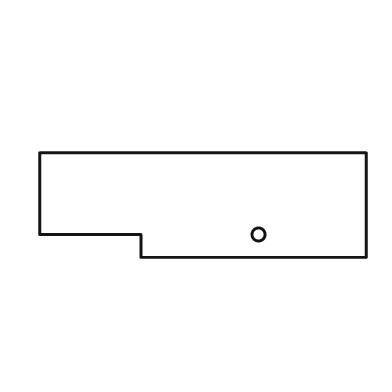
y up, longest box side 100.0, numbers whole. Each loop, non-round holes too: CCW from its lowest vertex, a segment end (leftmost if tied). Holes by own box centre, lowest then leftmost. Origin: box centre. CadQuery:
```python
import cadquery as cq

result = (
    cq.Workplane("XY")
    .moveTo(-19.0, -16.0)
    .lineTo(50.0, -16.0)
    .lineTo(50.0, 16.0)
    .lineTo(-50.0, 16.0)
    .lineTo(-50.0, -9.0)
    .lineTo(-19.0, -9.0)
    .close()
    .moveTo(17.0, -9.0)
    .circle(2.0)
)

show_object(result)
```